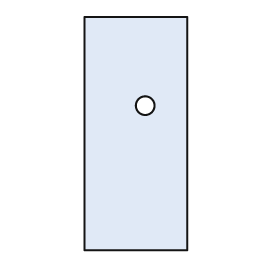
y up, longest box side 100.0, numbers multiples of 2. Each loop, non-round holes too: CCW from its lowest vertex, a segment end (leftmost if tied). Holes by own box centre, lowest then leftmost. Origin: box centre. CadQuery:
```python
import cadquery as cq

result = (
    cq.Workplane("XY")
    .moveTo(-22.0, -50.0)
    .lineTo(22.0, -50.0)
    .lineTo(22.0, 50.0)
    .lineTo(-22.0, 50.0)
    .close()
    .moveTo(4.0, 12.0)
    .circle(4.0)
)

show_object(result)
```